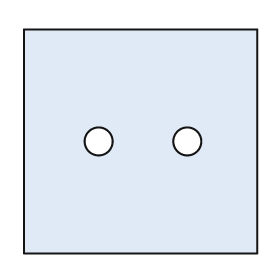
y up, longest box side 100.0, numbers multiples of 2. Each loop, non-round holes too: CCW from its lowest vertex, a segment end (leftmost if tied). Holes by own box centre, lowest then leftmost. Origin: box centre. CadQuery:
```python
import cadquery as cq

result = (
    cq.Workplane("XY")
    .moveTo(-50.0, -48.0)
    .lineTo(50.0, -48.0)
    .lineTo(50.0, 48.0)
    .lineTo(-50.0, 48.0)
    .close()
    .moveTo(-18.0, 0.0)
    .circle(6.0)
    .moveTo(20.0, 0.0)
    .circle(6.0)
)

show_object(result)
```